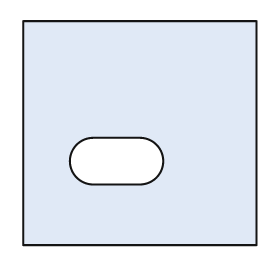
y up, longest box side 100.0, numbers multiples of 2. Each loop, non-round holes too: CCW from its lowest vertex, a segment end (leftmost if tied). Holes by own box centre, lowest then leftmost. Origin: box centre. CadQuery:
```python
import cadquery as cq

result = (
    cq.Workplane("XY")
    .moveTo(-50.0, -48.0)
    .lineTo(50.0, -48.0)
    .lineTo(50.0, 48.0)
    .lineTo(-50.0, 48.0)
    .close()
    .moveTo(-20.0, -22.0)
    .lineTo(0.0, -22.0)
    .threePointArc((10.0, -12.0), (0.0, -2.0))
    .lineTo(-20.0, -2.0)
    .threePointArc((-30.0, -12.0), (-20.0, -22.0))
    .close()
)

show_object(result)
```